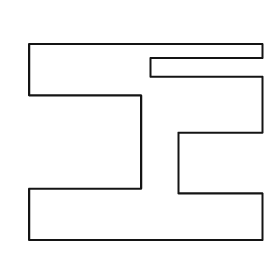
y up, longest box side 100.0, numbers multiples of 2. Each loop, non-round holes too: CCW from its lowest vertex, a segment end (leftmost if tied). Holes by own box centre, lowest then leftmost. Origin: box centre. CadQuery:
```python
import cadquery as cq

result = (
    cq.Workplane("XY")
    .moveTo(-50.0, -42.0)
    .lineTo(50.0, -42.0)
    .lineTo(50.0, -22.0)
    .lineTo(14.0, -22.0)
    .lineTo(14.0, 4.0)
    .lineTo(50.0, 4.0)
    .lineTo(50.0, 28.0)
    .lineTo(2.0, 28.0)
    .lineTo(2.0, 36.0)
    .lineTo(50.0, 36.0)
    .lineTo(50.0, 42.0)
    .lineTo(-50.0, 42.0)
    .lineTo(-50.0, 20.0)
    .lineTo(-2.0, 20.0)
    .lineTo(-2.0, -20.0)
    .lineTo(-50.0, -20.0)
    .close()
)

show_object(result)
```